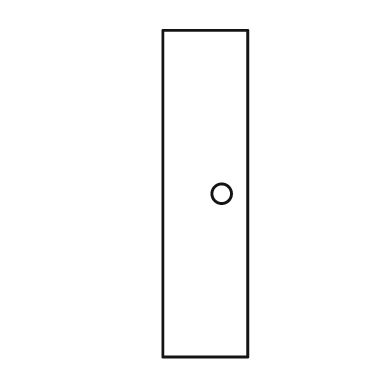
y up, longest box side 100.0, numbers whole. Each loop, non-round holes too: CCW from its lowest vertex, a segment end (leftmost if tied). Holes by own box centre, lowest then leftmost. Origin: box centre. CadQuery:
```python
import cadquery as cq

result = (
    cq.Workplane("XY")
    .moveTo(-13.0, -50.0)
    .lineTo(13.0, -50.0)
    .lineTo(13.0, 50.0)
    .lineTo(-13.0, 50.0)
    .close()
    .moveTo(5.0, 0.0)
    .circle(3.0)
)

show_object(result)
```